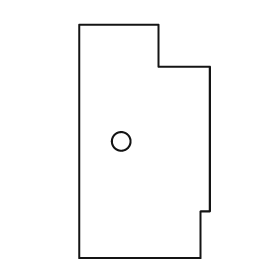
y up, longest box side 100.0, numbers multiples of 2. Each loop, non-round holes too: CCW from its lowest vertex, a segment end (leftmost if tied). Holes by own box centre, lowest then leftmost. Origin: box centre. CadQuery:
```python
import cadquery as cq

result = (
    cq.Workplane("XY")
    .moveTo(-28.0, -50.0)
    .lineTo(24.0, -50.0)
    .lineTo(24.0, -30.0)
    .lineTo(28.0, -30.0)
    .lineTo(28.0, 32.0)
    .lineTo(6.0, 32.0)
    .lineTo(6.0, 50.0)
    .lineTo(-28.0, 50.0)
    .close()
    .moveTo(-10.0, 0.0)
    .circle(4.0)
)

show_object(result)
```